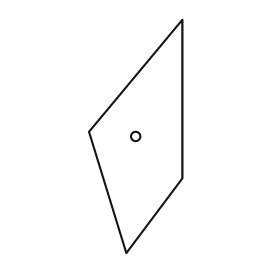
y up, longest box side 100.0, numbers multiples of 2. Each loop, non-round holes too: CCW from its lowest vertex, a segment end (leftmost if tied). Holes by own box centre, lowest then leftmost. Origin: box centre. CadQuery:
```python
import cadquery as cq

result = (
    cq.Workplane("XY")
    .moveTo(-4.0, -50.0)
    .lineTo(20.0, -18.0)
    .lineTo(20.0, 50.0)
    .lineTo(-20.0, 2.0)
    .close()
    .moveTo(0.0, 0.0)
    .circle(2.0)
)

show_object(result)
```